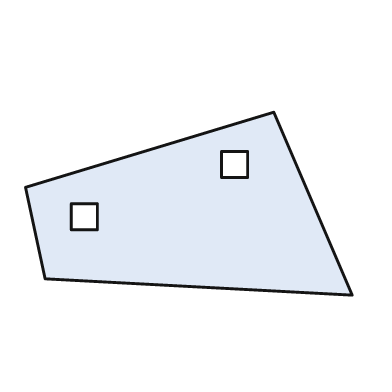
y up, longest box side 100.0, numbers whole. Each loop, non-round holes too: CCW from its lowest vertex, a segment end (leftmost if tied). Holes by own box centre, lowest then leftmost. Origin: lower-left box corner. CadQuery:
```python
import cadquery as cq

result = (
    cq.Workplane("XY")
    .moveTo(100.0, 0.0)
    .lineTo(76.0, 56.0)
    .lineTo(0.0, 33.0)
    .lineTo(6.0, 5.0)
    .close()
    .moveTo(14.0, 20.0)
    .lineTo(22.0, 20.0)
    .lineTo(22.0, 28.0)
    .lineTo(14.0, 28.0)
    .close()
    .moveTo(60.0, 36.0)
    .lineTo(68.0, 36.0)
    .lineTo(68.0, 44.0)
    .lineTo(60.0, 44.0)
    .close()
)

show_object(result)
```